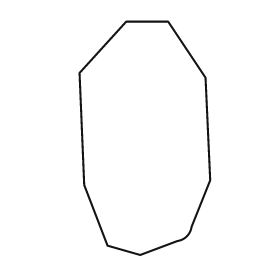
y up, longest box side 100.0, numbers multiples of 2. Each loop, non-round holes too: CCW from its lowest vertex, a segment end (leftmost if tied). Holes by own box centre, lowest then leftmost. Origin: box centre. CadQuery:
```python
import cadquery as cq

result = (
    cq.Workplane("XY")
    .moveTo(-2.0, -50.0)
    .lineTo(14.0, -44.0)
    .threePointArc((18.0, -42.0), (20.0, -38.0))
    .lineTo(28.0, -18.0)
    .lineTo(26.0, 26.0)
    .lineTo(10.0, 50.0)
    .lineTo(-8.0, 50.0)
    .lineTo(-28.0, 28.0)
    .lineTo(-26.0, -20.0)
    .lineTo(-16.0, -46.0)
    .close()
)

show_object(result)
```